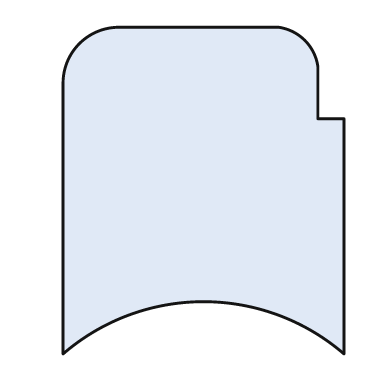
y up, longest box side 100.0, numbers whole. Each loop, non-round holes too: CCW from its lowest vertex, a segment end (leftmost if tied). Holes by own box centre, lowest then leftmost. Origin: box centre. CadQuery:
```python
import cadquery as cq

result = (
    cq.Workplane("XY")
    .moveTo(-43.0, -50.0)
    .threePointArc((0.0, -34.0), (43.0, -50.0))
    .lineTo(43.0, 22.0)
    .lineTo(35.0, 22.0)
    .lineTo(35.0, 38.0)
    .threePointArc((31.0, 46.0), (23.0, 50.0))
    .lineTo(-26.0, 50.0)
    .threePointArc((-38.0, 45.0), (-43.0, 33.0))
    .close()
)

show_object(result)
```